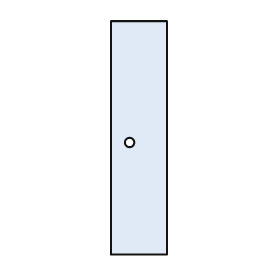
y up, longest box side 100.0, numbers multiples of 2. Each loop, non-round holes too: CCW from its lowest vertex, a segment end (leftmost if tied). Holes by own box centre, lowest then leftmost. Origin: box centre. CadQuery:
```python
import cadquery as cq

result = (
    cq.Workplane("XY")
    .moveTo(-12.0, -50.0)
    .lineTo(12.0, -50.0)
    .lineTo(12.0, 50.0)
    .lineTo(-12.0, 50.0)
    .close()
    .moveTo(-4.0, -2.0)
    .circle(2.0)
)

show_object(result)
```